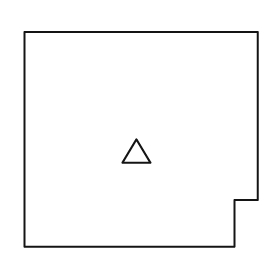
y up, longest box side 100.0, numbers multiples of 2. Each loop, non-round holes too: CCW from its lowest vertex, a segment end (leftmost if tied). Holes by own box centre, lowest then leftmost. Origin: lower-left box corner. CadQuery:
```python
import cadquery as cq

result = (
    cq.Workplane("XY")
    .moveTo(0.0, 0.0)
    .lineTo(90.0, 0.0)
    .lineTo(90.0, 20.0)
    .lineTo(100.0, 20.0)
    .lineTo(100.0, 92.0)
    .lineTo(0.0, 92.0)
    .close()
    .moveTo(42.0, 36.0)
    .lineTo(54.0, 36.0)
    .lineTo(48.0, 46.0)
    .close()
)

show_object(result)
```